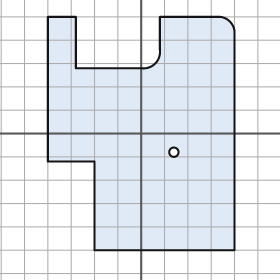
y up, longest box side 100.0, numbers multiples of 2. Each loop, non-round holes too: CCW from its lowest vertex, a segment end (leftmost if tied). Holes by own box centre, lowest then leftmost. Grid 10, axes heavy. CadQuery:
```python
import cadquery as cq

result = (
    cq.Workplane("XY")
    .moveTo(-20.0, -50.0)
    .lineTo(40.0, -50.0)
    .lineTo(40.0, 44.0)
    .threePointArc((38.0, 48.0), (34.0, 50.0))
    .lineTo(8.0, 50.0)
    .lineTo(8.0, 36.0)
    .threePointArc((6.0, 30.0), (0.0, 28.0))
    .lineTo(-28.0, 28.0)
    .lineTo(-28.0, 50.0)
    .lineTo(-40.0, 50.0)
    .lineTo(-40.0, -12.0)
    .lineTo(-20.0, -12.0)
    .close()
    .moveTo(14.0, -8.0)
    .circle(2.0)
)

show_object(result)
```